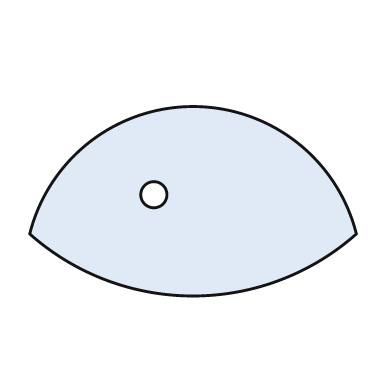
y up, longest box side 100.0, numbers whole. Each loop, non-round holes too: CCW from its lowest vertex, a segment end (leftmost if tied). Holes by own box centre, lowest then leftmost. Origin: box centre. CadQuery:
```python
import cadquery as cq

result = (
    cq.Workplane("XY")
    .moveTo(-50.0, -10.0)
    .threePointArc((0.0, -29.0), (50.0, -10.0))
    .threePointArc((0.0, 29.0), (-50.0, -10.0))
    .close()
    .moveTo(-12.0, 2.0)
    .circle(4.0)
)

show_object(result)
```